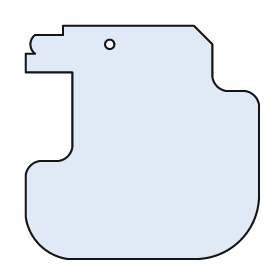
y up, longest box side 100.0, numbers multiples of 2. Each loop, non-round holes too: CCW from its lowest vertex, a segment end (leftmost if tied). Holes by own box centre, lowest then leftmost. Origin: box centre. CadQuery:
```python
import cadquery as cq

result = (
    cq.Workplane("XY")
    .moveTo(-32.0, -50.0)
    .lineTo(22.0, -50.0)
    .threePointArc((42.0, -42.0), (50.0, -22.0))
    .lineTo(50.0, 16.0)
    .threePointArc((48.0, 20.0), (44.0, 22.0))
    .lineTo(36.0, 22.0)
    .threePointArc((32.0, 24.0), (30.0, 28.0))
    .lineTo(30.0, 42.0)
    .lineTo(22.0, 50.0)
    .lineTo(-34.0, 50.0)
    .lineTo(-34.0, 46.0)
    .lineTo(-46.0, 46.0)
    .threePointArc((-48.0, 42.0), (-46.0, 38.0))
    .lineTo(-50.0, 38.0)
    .lineTo(-50.0, 30.0)
    .lineTo(-30.0, 30.0)
    .lineTo(-30.0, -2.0)
    .threePointArc((-32.0, -6.0), (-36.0, -8.0))
    .lineTo(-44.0, -8.0)
    .threePointArc((-48.0, -10.0), (-50.0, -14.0))
    .lineTo(-50.0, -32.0)
    .threePointArc((-44.0, -44.0), (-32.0, -50.0))
    .close()
    .moveTo(-14.0, 42.0)
    .circle(2.0)
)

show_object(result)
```